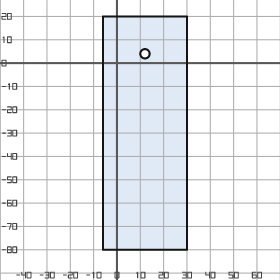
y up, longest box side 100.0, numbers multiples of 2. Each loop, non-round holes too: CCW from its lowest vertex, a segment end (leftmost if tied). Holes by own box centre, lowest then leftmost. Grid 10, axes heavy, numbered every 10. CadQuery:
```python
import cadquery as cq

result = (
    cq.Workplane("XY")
    .moveTo(-6.0, -80.0)
    .lineTo(30.0, -80.0)
    .lineTo(30.0, 20.0)
    .lineTo(-6.0, 20.0)
    .close()
    .moveTo(12.0, 4.0)
    .circle(2.0)
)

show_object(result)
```